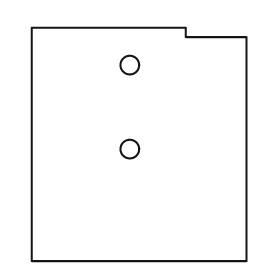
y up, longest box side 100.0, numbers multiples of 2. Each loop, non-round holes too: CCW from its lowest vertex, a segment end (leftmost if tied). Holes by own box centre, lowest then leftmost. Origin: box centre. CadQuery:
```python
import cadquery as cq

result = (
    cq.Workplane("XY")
    .moveTo(-46.0, -50.0)
    .lineTo(46.0, -50.0)
    .lineTo(46.0, 46.0)
    .lineTo(20.0, 46.0)
    .lineTo(20.0, 50.0)
    .lineTo(-46.0, 50.0)
    .close()
    .moveTo(-4.0, -2.0)
    .circle(4.0)
    .moveTo(-4.0, 34.0)
    .circle(4.0)
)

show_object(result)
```